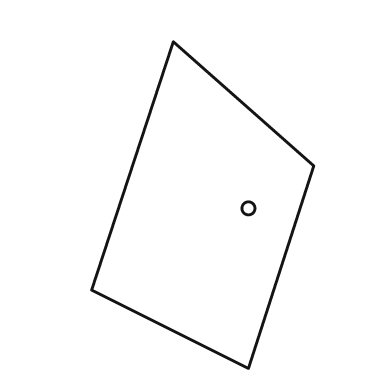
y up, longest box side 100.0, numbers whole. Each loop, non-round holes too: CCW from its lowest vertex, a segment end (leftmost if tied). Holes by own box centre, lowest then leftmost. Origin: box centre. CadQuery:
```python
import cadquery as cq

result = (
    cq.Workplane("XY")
    .moveTo(14.0, -50.0)
    .lineTo(34.0, 12.0)
    .lineTo(-9.0, 50.0)
    .lineTo(-34.0, -26.0)
    .close()
    .moveTo(14.0, -1.0)
    .circle(2.0)
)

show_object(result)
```